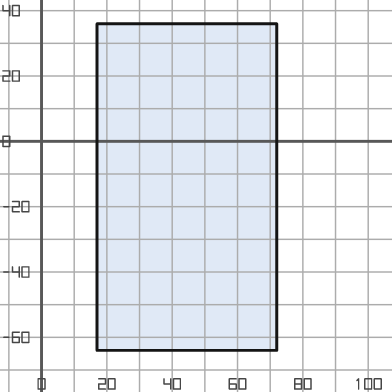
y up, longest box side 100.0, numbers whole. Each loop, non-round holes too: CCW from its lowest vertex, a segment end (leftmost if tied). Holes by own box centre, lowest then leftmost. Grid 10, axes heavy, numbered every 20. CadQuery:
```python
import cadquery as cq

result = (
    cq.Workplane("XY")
    .moveTo(17.0, -64.0)
    .lineTo(72.0, -64.0)
    .lineTo(72.0, 36.0)
    .lineTo(17.0, 36.0)
    .close()
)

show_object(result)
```